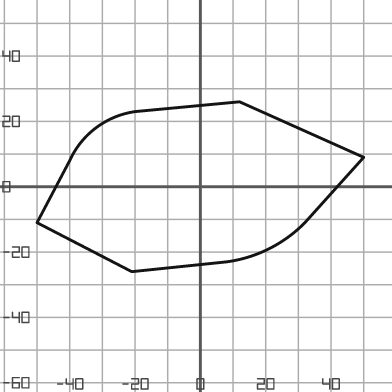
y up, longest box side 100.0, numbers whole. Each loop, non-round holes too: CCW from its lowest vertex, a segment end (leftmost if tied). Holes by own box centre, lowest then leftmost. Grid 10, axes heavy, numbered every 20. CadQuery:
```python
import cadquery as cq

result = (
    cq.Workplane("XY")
    .moveTo(-21.0, -26.0)
    .lineTo(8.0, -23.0)
    .threePointArc((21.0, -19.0), (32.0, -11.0))
    .lineTo(50.0, 9.0)
    .lineTo(12.0, 26.0)
    .lineTo(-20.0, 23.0)
    .threePointArc((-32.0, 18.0), (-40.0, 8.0))
    .lineTo(-50.0, -11.0)
    .close()
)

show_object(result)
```